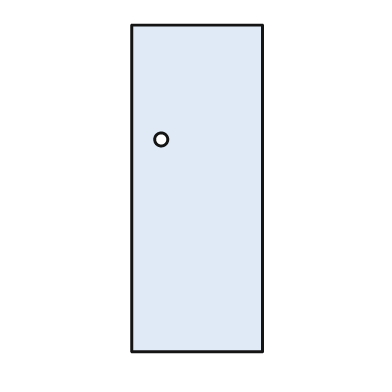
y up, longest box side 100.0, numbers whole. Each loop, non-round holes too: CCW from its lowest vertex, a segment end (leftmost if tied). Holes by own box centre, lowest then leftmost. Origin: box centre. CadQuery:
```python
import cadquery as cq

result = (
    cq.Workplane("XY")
    .moveTo(-20.0, -50.0)
    .lineTo(20.0, -50.0)
    .lineTo(20.0, 50.0)
    .lineTo(-20.0, 50.0)
    .close()
    .moveTo(-11.0, 15.0)
    .circle(2.0)
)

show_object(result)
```